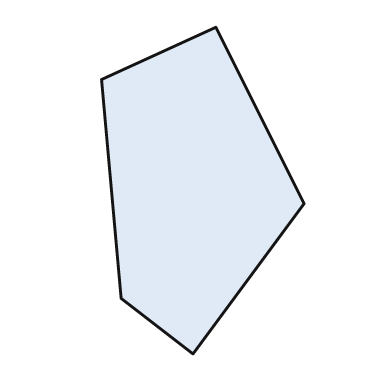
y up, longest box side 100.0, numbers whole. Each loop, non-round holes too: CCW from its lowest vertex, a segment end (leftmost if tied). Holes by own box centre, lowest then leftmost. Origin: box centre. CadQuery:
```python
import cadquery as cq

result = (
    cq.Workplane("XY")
    .moveTo(-3.0, -50.0)
    .lineTo(31.0, -4.0)
    .lineTo(4.0, 50.0)
    .lineTo(-31.0, 34.0)
    .lineTo(-25.0, -33.0)
    .close()
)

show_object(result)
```